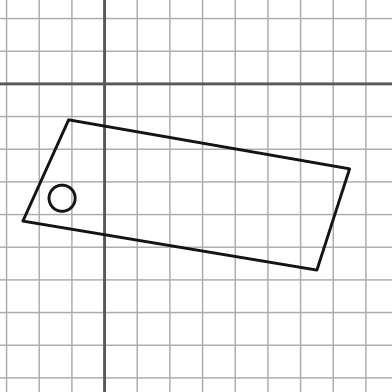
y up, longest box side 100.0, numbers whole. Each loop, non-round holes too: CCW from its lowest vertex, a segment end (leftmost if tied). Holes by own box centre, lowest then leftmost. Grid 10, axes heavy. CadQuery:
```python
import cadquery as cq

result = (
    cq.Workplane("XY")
    .moveTo(65.0, -57.0)
    .lineTo(75.0, -26.0)
    .lineTo(-11.0, -11.0)
    .lineTo(-25.0, -42.0)
    .close()
    .moveTo(-13.0, -35.0)
    .circle(4.0)
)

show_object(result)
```